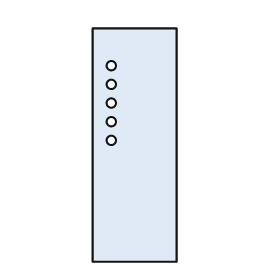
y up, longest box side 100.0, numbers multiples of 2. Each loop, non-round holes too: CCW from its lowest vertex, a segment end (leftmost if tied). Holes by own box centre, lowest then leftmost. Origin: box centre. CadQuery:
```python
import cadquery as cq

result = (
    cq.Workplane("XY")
    .moveTo(-18.0, -50.0)
    .lineTo(18.0, -50.0)
    .lineTo(18.0, 50.0)
    .lineTo(-18.0, 50.0)
    .close()
    .moveTo(-10.0, 2.0)
    .circle(2.0)
    .moveTo(-10.0, 10.0)
    .circle(2.0)
    .moveTo(-10.0, 18.0)
    .circle(2.0)
    .moveTo(-10.0, 26.0)
    .circle(2.0)
    .moveTo(-10.0, 34.0)
    .circle(2.0)
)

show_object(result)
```